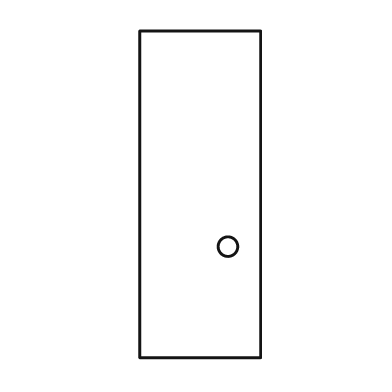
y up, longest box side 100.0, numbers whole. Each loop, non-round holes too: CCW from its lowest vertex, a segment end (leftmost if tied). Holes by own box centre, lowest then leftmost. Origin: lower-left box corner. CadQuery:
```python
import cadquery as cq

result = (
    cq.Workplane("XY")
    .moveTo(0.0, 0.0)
    .lineTo(37.0, 0.0)
    .lineTo(37.0, 100.0)
    .lineTo(0.0, 100.0)
    .close()
    .moveTo(27.0, 34.0)
    .circle(3.0)
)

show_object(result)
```